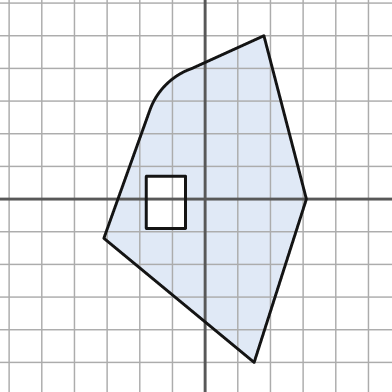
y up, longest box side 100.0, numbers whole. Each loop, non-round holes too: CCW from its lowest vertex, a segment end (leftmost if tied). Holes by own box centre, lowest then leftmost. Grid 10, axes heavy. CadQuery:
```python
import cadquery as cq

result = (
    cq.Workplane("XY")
    .moveTo(15.0, -50.0)
    .lineTo(31.0, 0.0)
    .lineTo(18.0, 50.0)
    .lineTo(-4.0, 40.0)
    .threePointArc((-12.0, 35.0), (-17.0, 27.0))
    .lineTo(-31.0, -12.0)
    .close()
    .moveTo(-18.0, -9.0)
    .lineTo(-6.0, -9.0)
    .lineTo(-6.0, 7.0)
    .lineTo(-18.0, 7.0)
    .close()
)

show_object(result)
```